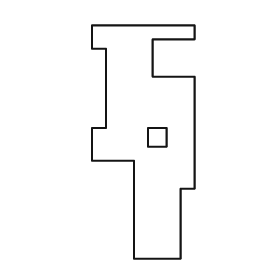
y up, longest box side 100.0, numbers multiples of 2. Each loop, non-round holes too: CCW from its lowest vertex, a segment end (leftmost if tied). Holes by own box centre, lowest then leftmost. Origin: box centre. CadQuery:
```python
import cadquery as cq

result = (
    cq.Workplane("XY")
    .moveTo(-4.0, -50.0)
    .lineTo(16.0, -50.0)
    .lineTo(16.0, -20.0)
    .lineTo(22.0, -20.0)
    .lineTo(22.0, 28.0)
    .lineTo(4.0, 28.0)
    .lineTo(4.0, 44.0)
    .lineTo(22.0, 44.0)
    .lineTo(22.0, 50.0)
    .lineTo(-22.0, 50.0)
    .lineTo(-22.0, 40.0)
    .lineTo(-16.0, 40.0)
    .lineTo(-16.0, 6.0)
    .lineTo(-22.0, 6.0)
    .lineTo(-22.0, -8.0)
    .lineTo(-4.0, -8.0)
    .close()
    .moveTo(2.0, -2.0)
    .lineTo(10.0, -2.0)
    .lineTo(10.0, 6.0)
    .lineTo(2.0, 6.0)
    .close()
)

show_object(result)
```